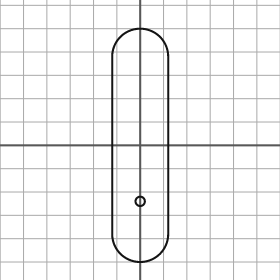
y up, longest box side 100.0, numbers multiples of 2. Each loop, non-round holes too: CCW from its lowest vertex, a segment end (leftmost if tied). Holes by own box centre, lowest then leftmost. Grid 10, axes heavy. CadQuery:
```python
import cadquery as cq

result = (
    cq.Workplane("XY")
    .moveTo(-12.0, -38.0)
    .threePointArc((0.0, -50.0), (12.0, -38.0))
    .lineTo(12.0, 38.0)
    .threePointArc((0.0, 50.0), (-12.0, 38.0))
    .close()
    .moveTo(0.0, -24.0)
    .circle(2.0)
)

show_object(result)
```